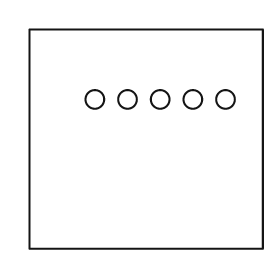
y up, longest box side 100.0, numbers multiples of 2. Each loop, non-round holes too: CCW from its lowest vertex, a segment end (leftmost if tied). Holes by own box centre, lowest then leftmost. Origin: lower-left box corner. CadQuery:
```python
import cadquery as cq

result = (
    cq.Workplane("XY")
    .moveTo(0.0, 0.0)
    .lineTo(100.0, 0.0)
    .lineTo(100.0, 94.0)
    .lineTo(0.0, 94.0)
    .close()
    .moveTo(28.0, 64.0)
    .circle(4.0)
    .moveTo(42.0, 64.0)
    .circle(4.0)
    .moveTo(56.0, 64.0)
    .circle(4.0)
    .moveTo(70.0, 64.0)
    .circle(4.0)
    .moveTo(84.0, 64.0)
    .circle(4.0)
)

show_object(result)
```